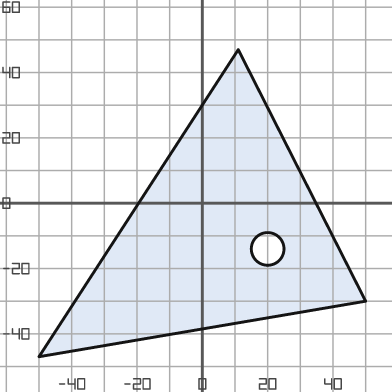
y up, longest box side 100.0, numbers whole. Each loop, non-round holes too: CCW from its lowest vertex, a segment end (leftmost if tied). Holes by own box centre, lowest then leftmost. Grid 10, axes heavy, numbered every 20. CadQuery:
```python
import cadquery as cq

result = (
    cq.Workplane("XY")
    .moveTo(-50.0, -47.0)
    .lineTo(50.0, -30.0)
    .lineTo(11.0, 47.0)
    .close()
    .moveTo(20.0, -14.0)
    .circle(5.0)
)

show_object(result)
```